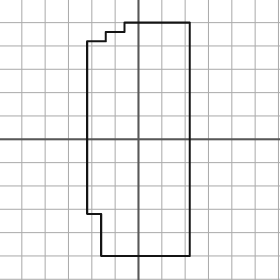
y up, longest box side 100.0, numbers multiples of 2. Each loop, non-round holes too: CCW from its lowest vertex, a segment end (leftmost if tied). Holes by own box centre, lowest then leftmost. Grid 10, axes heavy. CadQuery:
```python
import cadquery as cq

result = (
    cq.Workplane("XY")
    .moveTo(-16.0, -50.0)
    .lineTo(22.0, -50.0)
    .lineTo(22.0, 50.0)
    .lineTo(-6.0, 50.0)
    .lineTo(-6.0, 46.0)
    .lineTo(-14.0, 46.0)
    .lineTo(-14.0, 42.0)
    .lineTo(-22.0, 42.0)
    .lineTo(-22.0, -32.0)
    .lineTo(-16.0, -32.0)
    .close()
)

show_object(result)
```